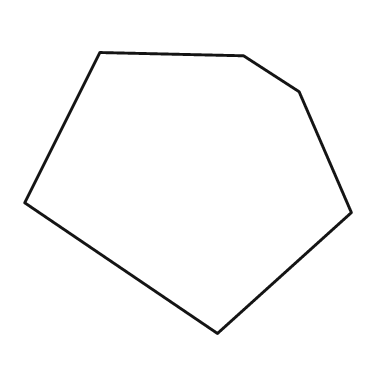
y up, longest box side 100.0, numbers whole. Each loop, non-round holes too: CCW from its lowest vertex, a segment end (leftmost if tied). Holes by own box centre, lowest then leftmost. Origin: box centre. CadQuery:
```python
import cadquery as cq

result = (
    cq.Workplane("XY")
    .moveTo(9.0, -43.0)
    .lineTo(50.0, -6.0)
    .lineTo(34.0, 31.0)
    .lineTo(17.0, 42.0)
    .lineTo(-27.0, 43.0)
    .lineTo(-50.0, -3.0)
    .close()
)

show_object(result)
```